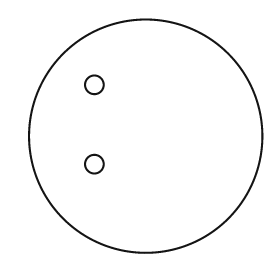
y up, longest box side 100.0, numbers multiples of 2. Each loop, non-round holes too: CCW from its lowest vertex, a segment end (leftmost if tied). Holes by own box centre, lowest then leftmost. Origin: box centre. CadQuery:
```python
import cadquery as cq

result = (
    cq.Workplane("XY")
    .moveTo(0.0, 0.0)
    .circle(50.0)
    .moveTo(-22.0, -12.0)
    .circle(4.0)
    .moveTo(-22.0, 22.0)
    .circle(4.0)
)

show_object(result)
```